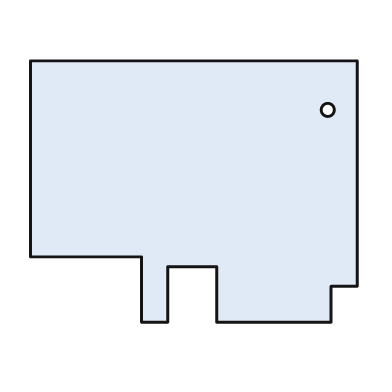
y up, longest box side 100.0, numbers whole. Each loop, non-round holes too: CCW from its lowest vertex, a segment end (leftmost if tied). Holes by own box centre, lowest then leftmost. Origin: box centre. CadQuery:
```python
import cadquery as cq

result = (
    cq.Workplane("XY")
    .moveTo(-16.0, -40.0)
    .lineTo(-8.0, -40.0)
    .lineTo(-8.0, -23.0)
    .lineTo(7.0, -23.0)
    .lineTo(7.0, -40.0)
    .lineTo(42.0, -40.0)
    .lineTo(42.0, -29.0)
    .lineTo(50.0, -29.0)
    .lineTo(50.0, 40.0)
    .lineTo(-50.0, 40.0)
    .lineTo(-50.0, -20.0)
    .lineTo(-16.0, -20.0)
    .close()
    .moveTo(41.0, 25.0)
    .circle(2.0)
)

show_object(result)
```